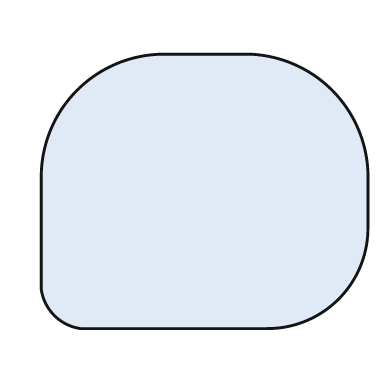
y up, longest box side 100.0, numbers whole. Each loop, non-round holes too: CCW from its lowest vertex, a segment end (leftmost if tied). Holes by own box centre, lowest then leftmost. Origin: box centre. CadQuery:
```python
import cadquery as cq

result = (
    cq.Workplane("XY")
    .moveTo(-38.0, -42.0)
    .lineTo(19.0, -42.0)
    .threePointArc((41.0, -33.0), (50.0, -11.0))
    .lineTo(50.0, 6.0)
    .threePointArc((39.0, 31.0), (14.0, 42.0))
    .lineTo(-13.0, 42.0)
    .threePointArc((-39.0, 31.0), (-50.0, 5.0))
    .lineTo(-50.0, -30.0)
    .threePointArc((-46.0, -38.0), (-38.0, -42.0))
    .close()
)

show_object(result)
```